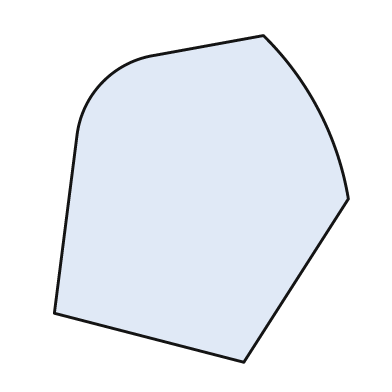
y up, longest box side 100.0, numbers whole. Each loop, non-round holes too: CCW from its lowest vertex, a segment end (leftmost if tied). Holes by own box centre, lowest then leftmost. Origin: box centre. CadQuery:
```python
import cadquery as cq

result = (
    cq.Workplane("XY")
    .moveTo(13.0, -50.0)
    .lineTo(45.0, 0.0)
    .threePointArc((36.0, 27.0), (19.0, 50.0))
    .lineTo(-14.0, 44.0)
    .threePointArc((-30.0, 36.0), (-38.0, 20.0))
    .lineTo(-45.0, -35.0)
    .close()
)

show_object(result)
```